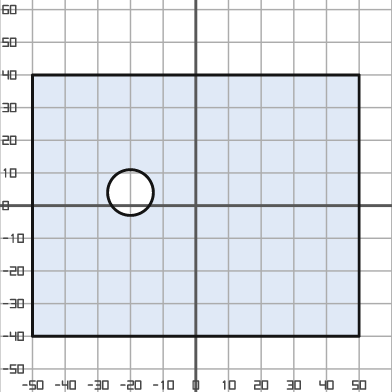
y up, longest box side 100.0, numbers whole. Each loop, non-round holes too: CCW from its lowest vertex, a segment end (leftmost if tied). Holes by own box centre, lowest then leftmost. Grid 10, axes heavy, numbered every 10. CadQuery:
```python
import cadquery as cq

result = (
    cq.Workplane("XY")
    .moveTo(-50.0, -40.0)
    .lineTo(50.0, -40.0)
    .lineTo(50.0, 40.0)
    .lineTo(-50.0, 40.0)
    .close()
    .moveTo(-20.0, 4.0)
    .circle(7.0)
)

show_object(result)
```